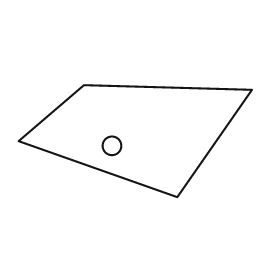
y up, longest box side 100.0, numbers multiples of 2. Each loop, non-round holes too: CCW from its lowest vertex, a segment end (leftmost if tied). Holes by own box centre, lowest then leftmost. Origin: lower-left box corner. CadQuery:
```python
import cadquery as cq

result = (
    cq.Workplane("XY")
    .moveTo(68.0, 0.0)
    .lineTo(100.0, 46.0)
    .lineTo(28.0, 48.0)
    .lineTo(0.0, 24.0)
    .close()
    .moveTo(40.0, 22.0)
    .circle(4.0)
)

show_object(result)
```